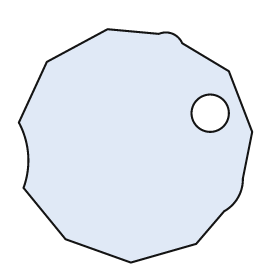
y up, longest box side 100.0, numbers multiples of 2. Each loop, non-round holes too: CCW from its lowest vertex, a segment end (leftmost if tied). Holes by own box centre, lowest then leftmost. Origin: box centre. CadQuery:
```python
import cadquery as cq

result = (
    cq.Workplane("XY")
    .moveTo(-2.0, -50.0)
    .lineTo(26.0, -42.0)
    .lineTo(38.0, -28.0)
    .threePointArc((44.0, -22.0), (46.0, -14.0))
    .lineTo(50.0, 6.0)
    .lineTo(40.0, 32.0)
    .lineTo(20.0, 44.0)
    .threePointArc((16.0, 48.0), (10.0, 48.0))
    .lineTo(-12.0, 50.0)
    .lineTo(-38.0, 36.0)
    .lineTo(-50.0, 10.0)
    .threePointArc((-46.0, -4.0), (-48.0, -18.0))
    .lineTo(-30.0, -40.0)
    .close()
    .moveTo(32.0, 14.0)
    .circle(8.0)
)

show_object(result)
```